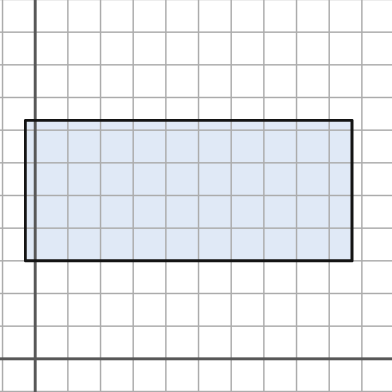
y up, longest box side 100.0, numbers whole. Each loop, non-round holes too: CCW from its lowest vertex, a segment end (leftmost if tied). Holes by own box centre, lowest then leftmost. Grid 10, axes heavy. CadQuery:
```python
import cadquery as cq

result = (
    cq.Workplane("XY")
    .moveTo(-3.0, 30.0)
    .lineTo(97.0, 30.0)
    .lineTo(97.0, 73.0)
    .lineTo(-3.0, 73.0)
    .close()
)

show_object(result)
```